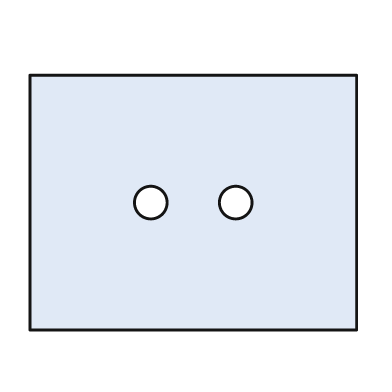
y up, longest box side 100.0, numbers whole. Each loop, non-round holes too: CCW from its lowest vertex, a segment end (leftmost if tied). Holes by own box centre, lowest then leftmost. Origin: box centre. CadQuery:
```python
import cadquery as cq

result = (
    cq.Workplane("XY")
    .moveTo(-50.0, -39.0)
    .lineTo(50.0, -39.0)
    .lineTo(50.0, 39.0)
    .lineTo(-50.0, 39.0)
    .close()
    .moveTo(-13.0, 0.0)
    .circle(5.0)
    .moveTo(13.0, 0.0)
    .circle(5.0)
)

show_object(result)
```